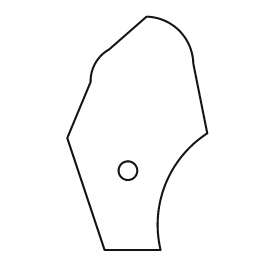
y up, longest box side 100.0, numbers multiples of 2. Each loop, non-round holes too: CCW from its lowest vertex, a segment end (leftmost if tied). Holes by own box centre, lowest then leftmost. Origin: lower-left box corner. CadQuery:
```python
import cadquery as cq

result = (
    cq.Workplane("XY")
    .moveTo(16.0, 0.0)
    .lineTo(40.0, 0.0)
    .threePointArc((42.0, 28.0), (60.0, 50.0))
    .lineTo(54.0, 80.0)
    .threePointArc((48.0, 94.0), (34.0, 100.0))
    .lineTo(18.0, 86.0)
    .threePointArc((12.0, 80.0), (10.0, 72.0))
    .lineTo(0.0, 48.0)
    .close()
    .moveTo(26.0, 34.0)
    .circle(4.0)
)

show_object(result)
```